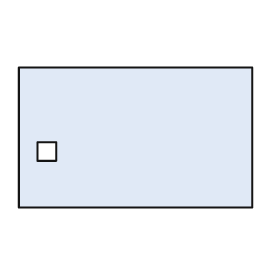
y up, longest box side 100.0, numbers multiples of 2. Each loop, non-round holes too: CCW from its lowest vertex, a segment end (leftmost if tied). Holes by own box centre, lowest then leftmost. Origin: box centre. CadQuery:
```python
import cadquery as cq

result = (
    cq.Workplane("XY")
    .moveTo(-50.0, -30.0)
    .lineTo(50.0, -30.0)
    .lineTo(50.0, 30.0)
    .lineTo(-50.0, 30.0)
    .close()
    .moveTo(-42.0, -10.0)
    .lineTo(-34.0, -10.0)
    .lineTo(-34.0, -2.0)
    .lineTo(-42.0, -2.0)
    .close()
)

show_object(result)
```